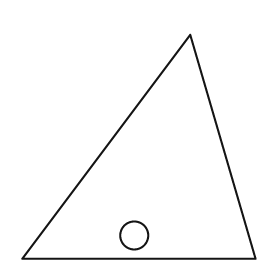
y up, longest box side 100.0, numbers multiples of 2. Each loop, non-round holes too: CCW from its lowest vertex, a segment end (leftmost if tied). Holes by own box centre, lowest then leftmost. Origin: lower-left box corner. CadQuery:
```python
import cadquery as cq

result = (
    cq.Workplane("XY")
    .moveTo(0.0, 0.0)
    .lineTo(100.0, 0.0)
    .lineTo(72.0, 96.0)
    .close()
    .moveTo(48.0, 10.0)
    .circle(6.0)
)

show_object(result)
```